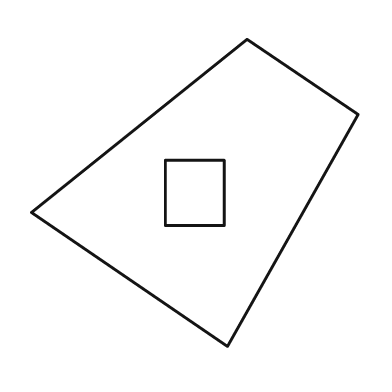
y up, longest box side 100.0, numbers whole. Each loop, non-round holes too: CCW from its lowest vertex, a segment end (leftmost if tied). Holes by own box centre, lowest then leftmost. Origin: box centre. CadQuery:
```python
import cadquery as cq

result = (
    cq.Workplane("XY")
    .moveTo(10.0, -47.0)
    .lineTo(50.0, 24.0)
    .lineTo(16.0, 47.0)
    .lineTo(-50.0, -6.0)
    .close()
    .moveTo(-9.0, -10.0)
    .lineTo(9.0, -10.0)
    .lineTo(9.0, 10.0)
    .lineTo(-9.0, 10.0)
    .close()
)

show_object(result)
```